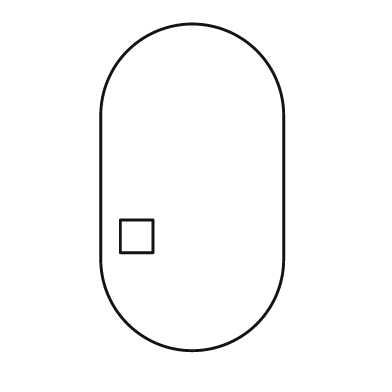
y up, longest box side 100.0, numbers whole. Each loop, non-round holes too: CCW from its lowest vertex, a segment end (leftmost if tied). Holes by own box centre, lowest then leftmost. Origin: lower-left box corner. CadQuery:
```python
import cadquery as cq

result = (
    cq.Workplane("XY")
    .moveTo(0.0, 28.0)
    .threePointArc((28.0, 0.0), (56.0, 28.0))
    .lineTo(56.0, 72.0)
    .threePointArc((28.0, 100.0), (0.0, 72.0))
    .close()
    .moveTo(6.0, 30.0)
    .lineTo(16.0, 30.0)
    .lineTo(16.0, 40.0)
    .lineTo(6.0, 40.0)
    .close()
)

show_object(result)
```